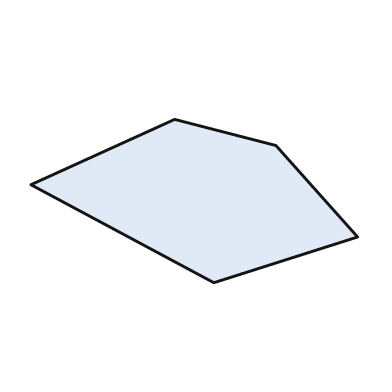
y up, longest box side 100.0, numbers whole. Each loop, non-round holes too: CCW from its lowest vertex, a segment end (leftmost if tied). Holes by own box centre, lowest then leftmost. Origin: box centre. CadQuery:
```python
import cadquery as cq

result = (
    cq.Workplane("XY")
    .moveTo(6.0, -25.0)
    .lineTo(50.0, -11.0)
    .lineTo(25.0, 17.0)
    .lineTo(-6.0, 25.0)
    .lineTo(-50.0, 5.0)
    .close()
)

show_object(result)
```